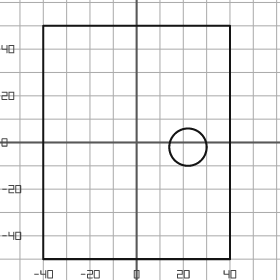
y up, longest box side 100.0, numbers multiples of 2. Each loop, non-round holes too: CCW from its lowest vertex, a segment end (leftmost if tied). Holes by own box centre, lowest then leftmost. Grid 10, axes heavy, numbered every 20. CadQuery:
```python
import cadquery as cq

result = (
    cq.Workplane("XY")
    .moveTo(-40.0, -50.0)
    .lineTo(40.0, -50.0)
    .lineTo(40.0, 50.0)
    .lineTo(-40.0, 50.0)
    .close()
    .moveTo(22.0, -2.0)
    .circle(8.0)
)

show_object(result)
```